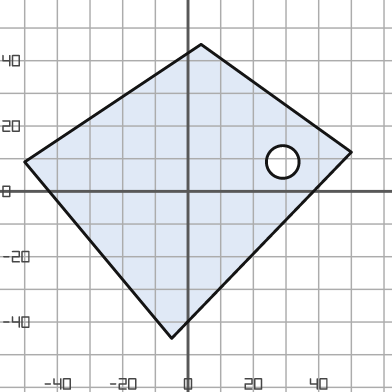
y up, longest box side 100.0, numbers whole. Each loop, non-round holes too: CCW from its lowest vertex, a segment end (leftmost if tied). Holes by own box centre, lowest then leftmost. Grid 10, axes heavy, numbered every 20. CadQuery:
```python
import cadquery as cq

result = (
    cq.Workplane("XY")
    .moveTo(-5.0, -45.0)
    .lineTo(50.0, 12.0)
    .lineTo(4.0, 45.0)
    .lineTo(-50.0, 9.0)
    .close()
    .moveTo(29.0, 9.0)
    .circle(5.0)
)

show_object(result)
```